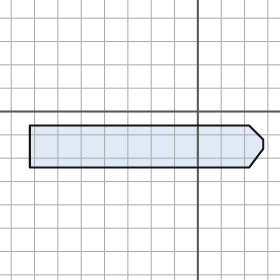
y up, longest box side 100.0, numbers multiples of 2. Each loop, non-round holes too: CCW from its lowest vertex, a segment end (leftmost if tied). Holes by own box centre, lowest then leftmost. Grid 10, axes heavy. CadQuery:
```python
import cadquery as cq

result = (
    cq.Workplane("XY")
    .moveTo(-72.0, -24.0)
    .lineTo(22.0, -24.0)
    .lineTo(28.0, -16.0)
    .lineTo(28.0, -12.0)
    .lineTo(22.0, -6.0)
    .lineTo(-72.0, -6.0)
    .close()
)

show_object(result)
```